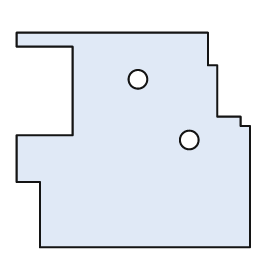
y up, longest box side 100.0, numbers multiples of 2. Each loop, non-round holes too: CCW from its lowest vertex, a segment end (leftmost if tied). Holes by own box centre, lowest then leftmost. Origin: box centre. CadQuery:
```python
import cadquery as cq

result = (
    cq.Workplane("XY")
    .moveTo(-40.0, -46.0)
    .lineTo(50.0, -46.0)
    .lineTo(50.0, 6.0)
    .lineTo(46.0, 6.0)
    .lineTo(46.0, 10.0)
    .lineTo(36.0, 10.0)
    .lineTo(36.0, 32.0)
    .lineTo(32.0, 32.0)
    .lineTo(32.0, 46.0)
    .lineTo(-50.0, 46.0)
    .lineTo(-50.0, 40.0)
    .lineTo(-26.0, 40.0)
    .lineTo(-26.0, 2.0)
    .lineTo(-50.0, 2.0)
    .lineTo(-50.0, -18.0)
    .lineTo(-40.0, -18.0)
    .close()
    .moveTo(24.0, 0.0)
    .circle(4.0)
    .moveTo(2.0, 26.0)
    .circle(4.0)
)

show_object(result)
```